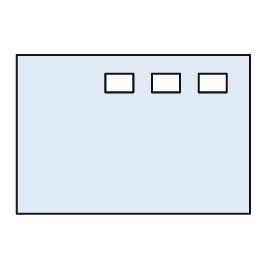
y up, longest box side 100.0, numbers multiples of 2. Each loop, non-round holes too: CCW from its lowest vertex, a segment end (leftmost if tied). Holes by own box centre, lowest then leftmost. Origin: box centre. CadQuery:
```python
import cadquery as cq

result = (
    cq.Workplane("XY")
    .moveTo(-50.0, -34.0)
    .lineTo(50.0, -34.0)
    .lineTo(50.0, 34.0)
    .lineTo(-50.0, 34.0)
    .close()
    .moveTo(-12.0, 18.0)
    .lineTo(0.0, 18.0)
    .lineTo(0.0, 26.0)
    .lineTo(-12.0, 26.0)
    .close()
    .moveTo(8.0, 18.0)
    .lineTo(20.0, 18.0)
    .lineTo(20.0, 26.0)
    .lineTo(8.0, 26.0)
    .close()
    .moveTo(28.0, 18.0)
    .lineTo(40.0, 18.0)
    .lineTo(40.0, 26.0)
    .lineTo(28.0, 26.0)
    .close()
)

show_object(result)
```